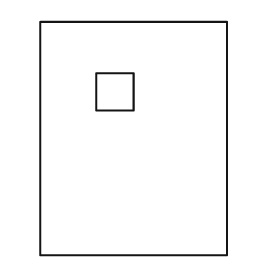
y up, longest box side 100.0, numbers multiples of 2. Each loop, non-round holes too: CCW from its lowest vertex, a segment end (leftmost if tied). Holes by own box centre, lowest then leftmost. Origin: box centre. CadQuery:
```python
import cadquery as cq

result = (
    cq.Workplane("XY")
    .moveTo(-40.0, -50.0)
    .lineTo(40.0, -50.0)
    .lineTo(40.0, 50.0)
    .lineTo(-40.0, 50.0)
    .close()
    .moveTo(-16.0, 12.0)
    .lineTo(0.0, 12.0)
    .lineTo(0.0, 28.0)
    .lineTo(-16.0, 28.0)
    .close()
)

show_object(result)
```